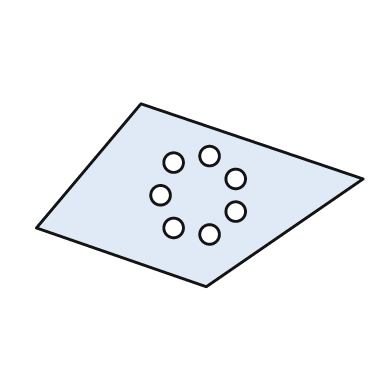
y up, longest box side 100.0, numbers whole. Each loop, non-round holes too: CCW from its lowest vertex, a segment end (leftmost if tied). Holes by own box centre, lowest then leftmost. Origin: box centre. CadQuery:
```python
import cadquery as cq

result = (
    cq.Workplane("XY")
    .moveTo(2.0, -28.0)
    .lineTo(50.0, 5.0)
    .lineTo(-18.0, 28.0)
    .lineTo(-50.0, -10.0)
    .close()
    .moveTo(3.0, -12.0)
    .circle(3.0)
    .moveTo(-8.0, -10.0)
    .circle(3.0)
    .moveTo(11.0, -5.0)
    .circle(3.0)
    .moveTo(-12.0, 0.0)
    .circle(3.0)
    .moveTo(11.0, 5.0)
    .circle(3.0)
    .moveTo(-8.0, 10.0)
    .circle(3.0)
    .moveTo(3.0, 12.0)
    .circle(3.0)
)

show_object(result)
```